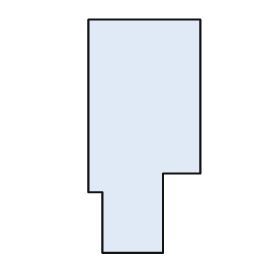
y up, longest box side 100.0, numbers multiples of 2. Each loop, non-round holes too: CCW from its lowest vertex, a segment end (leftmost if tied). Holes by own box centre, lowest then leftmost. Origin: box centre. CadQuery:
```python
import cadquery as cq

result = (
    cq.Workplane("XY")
    .moveTo(-18.0, -50.0)
    .lineTo(8.0, -50.0)
    .lineTo(8.0, -16.0)
    .lineTo(24.0, -16.0)
    .lineTo(24.0, 50.0)
    .lineTo(-24.0, 50.0)
    .lineTo(-24.0, -24.0)
    .lineTo(-18.0, -24.0)
    .close()
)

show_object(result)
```